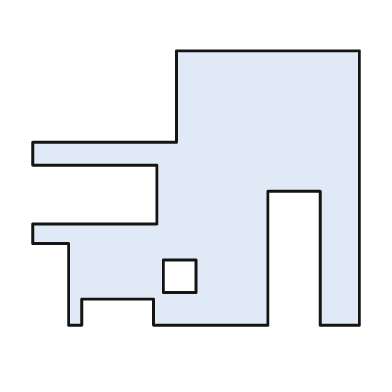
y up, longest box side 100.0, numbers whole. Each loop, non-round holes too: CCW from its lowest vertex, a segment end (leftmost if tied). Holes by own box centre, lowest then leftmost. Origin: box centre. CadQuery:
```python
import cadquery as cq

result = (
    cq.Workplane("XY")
    .moveTo(-39.0, -42.0)
    .lineTo(-35.0, -42.0)
    .lineTo(-35.0, -34.0)
    .lineTo(-13.0, -34.0)
    .lineTo(-13.0, -42.0)
    .lineTo(22.0, -42.0)
    .lineTo(22.0, -1.0)
    .lineTo(38.0, -1.0)
    .lineTo(38.0, -42.0)
    .lineTo(50.0, -42.0)
    .lineTo(50.0, 42.0)
    .lineTo(-6.0, 42.0)
    .lineTo(-6.0, 14.0)
    .lineTo(-50.0, 14.0)
    .lineTo(-50.0, 7.0)
    .lineTo(-12.0, 7.0)
    .lineTo(-12.0, -11.0)
    .lineTo(-50.0, -11.0)
    .lineTo(-50.0, -17.0)
    .lineTo(-39.0, -17.0)
    .close()
    .moveTo(-10.0, -32.0)
    .lineTo(0.0, -32.0)
    .lineTo(0.0, -22.0)
    .lineTo(-10.0, -22.0)
    .close()
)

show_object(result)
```